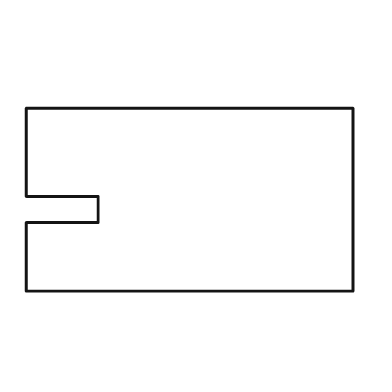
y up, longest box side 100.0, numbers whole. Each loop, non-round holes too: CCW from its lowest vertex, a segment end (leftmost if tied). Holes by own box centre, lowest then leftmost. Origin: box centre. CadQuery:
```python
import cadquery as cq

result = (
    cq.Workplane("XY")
    .moveTo(-50.0, -28.0)
    .lineTo(50.0, -28.0)
    .lineTo(50.0, 28.0)
    .lineTo(-50.0, 28.0)
    .lineTo(-50.0, 1.0)
    .lineTo(-28.0, 1.0)
    .lineTo(-28.0, -7.0)
    .lineTo(-50.0, -7.0)
    .close()
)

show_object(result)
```